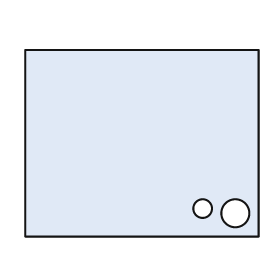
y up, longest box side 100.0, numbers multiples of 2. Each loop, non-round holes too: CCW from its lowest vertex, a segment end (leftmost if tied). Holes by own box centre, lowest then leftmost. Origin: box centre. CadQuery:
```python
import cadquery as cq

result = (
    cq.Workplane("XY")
    .moveTo(-50.0, -40.0)
    .lineTo(50.0, -40.0)
    .lineTo(50.0, 40.0)
    .lineTo(-50.0, 40.0)
    .close()
    .moveTo(40.0, -30.0)
    .circle(6.0)
    .moveTo(26.0, -28.0)
    .circle(4.0)
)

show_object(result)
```